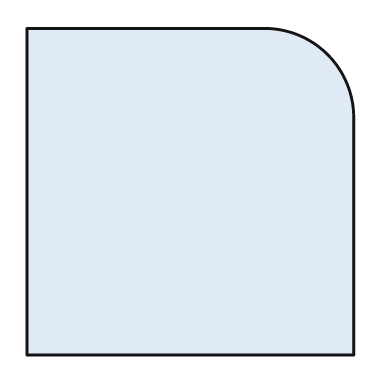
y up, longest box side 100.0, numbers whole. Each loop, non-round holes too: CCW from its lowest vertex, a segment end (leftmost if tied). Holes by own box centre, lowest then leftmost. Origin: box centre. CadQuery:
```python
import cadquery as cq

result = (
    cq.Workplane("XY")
    .moveTo(-50.0, -50.0)
    .lineTo(50.0, -50.0)
    .lineTo(50.0, 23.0)
    .threePointArc((42.0, 42.0), (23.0, 50.0))
    .lineTo(-50.0, 50.0)
    .close()
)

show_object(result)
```